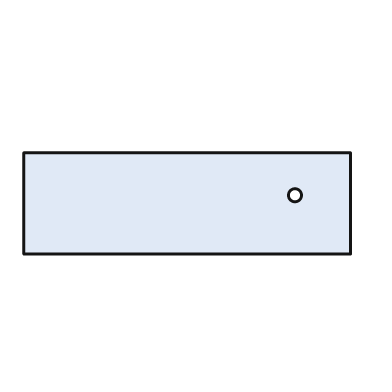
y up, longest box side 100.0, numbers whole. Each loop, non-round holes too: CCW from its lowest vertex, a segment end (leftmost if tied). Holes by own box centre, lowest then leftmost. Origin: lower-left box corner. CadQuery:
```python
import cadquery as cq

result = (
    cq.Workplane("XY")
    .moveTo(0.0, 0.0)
    .lineTo(100.0, 0.0)
    .lineTo(100.0, 31.0)
    .lineTo(0.0, 31.0)
    .close()
    .moveTo(83.0, 18.0)
    .circle(2.0)
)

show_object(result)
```